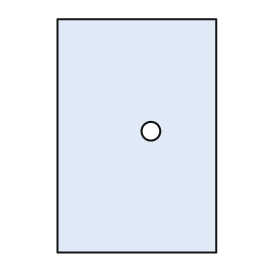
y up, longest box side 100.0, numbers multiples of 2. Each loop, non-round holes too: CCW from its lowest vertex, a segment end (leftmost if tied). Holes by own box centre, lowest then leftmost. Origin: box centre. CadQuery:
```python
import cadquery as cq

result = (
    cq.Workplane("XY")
    .moveTo(-34.0, -50.0)
    .lineTo(34.0, -50.0)
    .lineTo(34.0, 50.0)
    .lineTo(-34.0, 50.0)
    .close()
    .moveTo(6.0, 2.0)
    .circle(4.0)
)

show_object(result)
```